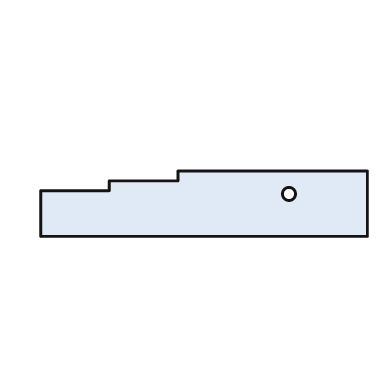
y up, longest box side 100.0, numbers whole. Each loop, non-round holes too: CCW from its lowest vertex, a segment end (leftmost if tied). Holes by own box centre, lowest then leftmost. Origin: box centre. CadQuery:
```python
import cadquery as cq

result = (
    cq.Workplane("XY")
    .moveTo(-50.0, -10.0)
    .lineTo(50.0, -10.0)
    .lineTo(50.0, 10.0)
    .lineTo(-8.0, 10.0)
    .lineTo(-8.0, 7.0)
    .lineTo(-29.0, 7.0)
    .lineTo(-29.0, 4.0)
    .lineTo(-50.0, 4.0)
    .close()
    .moveTo(26.0, 3.0)
    .circle(2.0)
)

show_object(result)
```